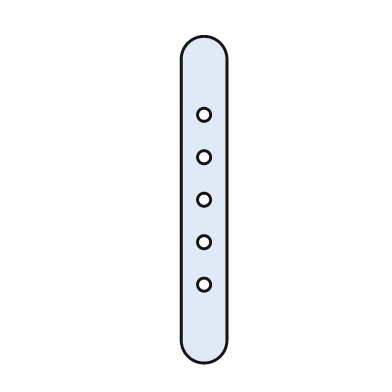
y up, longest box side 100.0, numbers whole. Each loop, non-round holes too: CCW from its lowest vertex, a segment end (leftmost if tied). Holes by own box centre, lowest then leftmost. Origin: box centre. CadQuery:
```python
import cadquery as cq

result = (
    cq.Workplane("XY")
    .moveTo(-7.0, -43.0)
    .threePointArc((0.0, -50.0), (7.0, -43.0))
    .lineTo(7.0, 43.0)
    .threePointArc((0.0, 50.0), (-7.0, 43.0))
    .close()
    .moveTo(0.0, -26.0)
    .circle(2.0)
    .moveTo(0.0, -13.0)
    .circle(2.0)
    .moveTo(0.0, 0.0)
    .circle(2.0)
    .moveTo(0.0, 13.0)
    .circle(2.0)
    .moveTo(0.0, 26.0)
    .circle(2.0)
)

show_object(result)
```